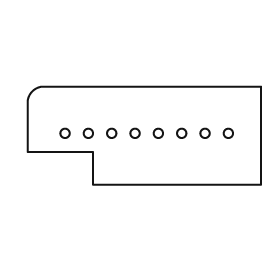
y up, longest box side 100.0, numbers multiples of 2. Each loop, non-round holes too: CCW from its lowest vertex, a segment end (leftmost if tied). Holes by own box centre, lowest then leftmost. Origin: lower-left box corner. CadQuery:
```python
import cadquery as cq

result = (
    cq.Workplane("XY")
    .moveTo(28.0, 0.0)
    .lineTo(100.0, 0.0)
    .lineTo(100.0, 42.0)
    .lineTo(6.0, 42.0)
    .threePointArc((2.0, 40.0), (0.0, 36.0))
    .lineTo(0.0, 14.0)
    .lineTo(28.0, 14.0)
    .close()
    .moveTo(16.0, 22.0)
    .circle(2.0)
    .moveTo(26.0, 22.0)
    .circle(2.0)
    .moveTo(36.0, 22.0)
    .circle(2.0)
    .moveTo(46.0, 22.0)
    .circle(2.0)
    .moveTo(56.0, 22.0)
    .circle(2.0)
    .moveTo(66.0, 22.0)
    .circle(2.0)
    .moveTo(76.0, 22.0)
    .circle(2.0)
    .moveTo(86.0, 22.0)
    .circle(2.0)
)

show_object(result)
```